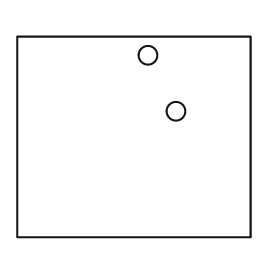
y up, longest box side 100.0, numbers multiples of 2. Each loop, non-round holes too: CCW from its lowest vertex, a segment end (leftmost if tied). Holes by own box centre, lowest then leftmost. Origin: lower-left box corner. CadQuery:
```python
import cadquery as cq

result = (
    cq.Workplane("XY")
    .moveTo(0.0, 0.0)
    .lineTo(100.0, 0.0)
    .lineTo(100.0, 86.0)
    .lineTo(0.0, 86.0)
    .close()
    .moveTo(68.0, 54.0)
    .circle(4.0)
    .moveTo(56.0, 78.0)
    .circle(4.0)
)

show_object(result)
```